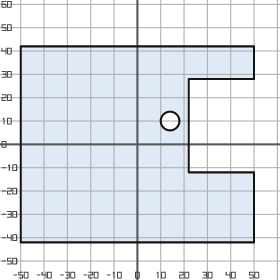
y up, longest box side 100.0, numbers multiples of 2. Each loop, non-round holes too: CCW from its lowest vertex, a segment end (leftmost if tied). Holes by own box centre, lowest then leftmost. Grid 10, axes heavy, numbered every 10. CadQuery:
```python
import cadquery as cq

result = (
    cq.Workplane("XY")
    .moveTo(-50.0, -42.0)
    .lineTo(50.0, -42.0)
    .lineTo(50.0, -12.0)
    .lineTo(22.0, -12.0)
    .lineTo(22.0, 28.0)
    .lineTo(50.0, 28.0)
    .lineTo(50.0, 42.0)
    .lineTo(-50.0, 42.0)
    .close()
    .moveTo(14.0, 10.0)
    .circle(4.0)
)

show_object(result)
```